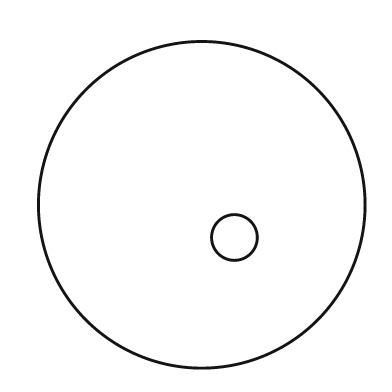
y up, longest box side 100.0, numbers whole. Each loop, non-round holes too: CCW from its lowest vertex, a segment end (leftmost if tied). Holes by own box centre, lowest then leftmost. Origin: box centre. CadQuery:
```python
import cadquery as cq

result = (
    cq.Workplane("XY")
    .moveTo(0.0, 0.0)
    .circle(50.0)
    .moveTo(10.0, -10.0)
    .circle(7.0)
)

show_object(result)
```